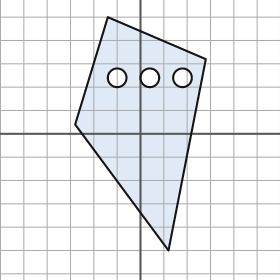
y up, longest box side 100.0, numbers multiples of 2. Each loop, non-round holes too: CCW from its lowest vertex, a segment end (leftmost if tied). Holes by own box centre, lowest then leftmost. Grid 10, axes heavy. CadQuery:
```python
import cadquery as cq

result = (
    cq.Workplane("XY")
    .moveTo(12.0, -50.0)
    .lineTo(28.0, 32.0)
    .lineTo(-14.0, 50.0)
    .lineTo(-28.0, 4.0)
    .close()
    .moveTo(-10.0, 24.0)
    .circle(4.0)
    .moveTo(4.0, 24.0)
    .circle(4.0)
    .moveTo(18.0, 24.0)
    .circle(4.0)
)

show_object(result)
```